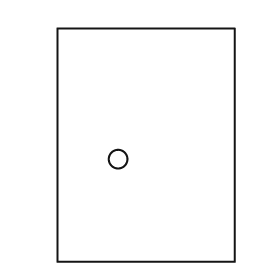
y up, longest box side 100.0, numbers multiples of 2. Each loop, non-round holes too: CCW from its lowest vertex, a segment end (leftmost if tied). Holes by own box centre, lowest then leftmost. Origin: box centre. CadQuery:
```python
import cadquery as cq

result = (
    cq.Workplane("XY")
    .moveTo(-38.0, -50.0)
    .lineTo(38.0, -50.0)
    .lineTo(38.0, 50.0)
    .lineTo(-38.0, 50.0)
    .close()
    .moveTo(-12.0, -6.0)
    .circle(4.0)
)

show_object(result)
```